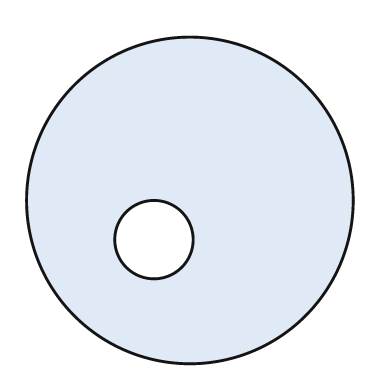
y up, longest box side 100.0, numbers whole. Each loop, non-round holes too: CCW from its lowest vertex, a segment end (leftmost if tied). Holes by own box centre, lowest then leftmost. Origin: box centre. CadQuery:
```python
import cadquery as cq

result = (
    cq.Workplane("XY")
    .moveTo(0.0, 0.0)
    .circle(50.0)
    .moveTo(-11.0, -12.0)
    .circle(12.0)
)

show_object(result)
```